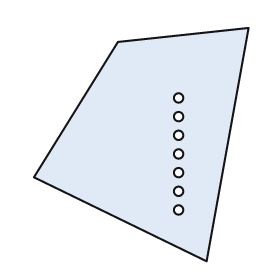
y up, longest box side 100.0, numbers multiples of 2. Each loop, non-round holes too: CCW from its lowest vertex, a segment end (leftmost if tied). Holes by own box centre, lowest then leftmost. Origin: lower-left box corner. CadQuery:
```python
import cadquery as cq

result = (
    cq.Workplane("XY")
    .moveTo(74.0, 0.0)
    .lineTo(92.0, 100.0)
    .lineTo(36.0, 94.0)
    .lineTo(0.0, 36.0)
    .close()
    .moveTo(62.0, 22.0)
    .circle(2.0)
    .moveTo(62.0, 30.0)
    .circle(2.0)
    .moveTo(62.0, 38.0)
    .circle(2.0)
    .moveTo(62.0, 46.0)
    .circle(2.0)
    .moveTo(62.0, 54.0)
    .circle(2.0)
    .moveTo(62.0, 62.0)
    .circle(2.0)
    .moveTo(62.0, 70.0)
    .circle(2.0)
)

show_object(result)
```